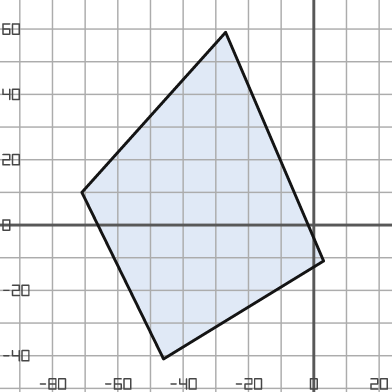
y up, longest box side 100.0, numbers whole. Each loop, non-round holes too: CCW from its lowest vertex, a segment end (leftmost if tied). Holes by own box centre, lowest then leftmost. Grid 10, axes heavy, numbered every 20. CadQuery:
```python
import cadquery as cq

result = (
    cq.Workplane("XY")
    .moveTo(-46.0, -41.0)
    .lineTo(3.0, -11.0)
    .lineTo(-27.0, 59.0)
    .lineTo(-71.0, 10.0)
    .close()
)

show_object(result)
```